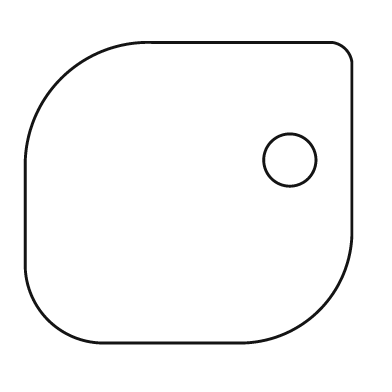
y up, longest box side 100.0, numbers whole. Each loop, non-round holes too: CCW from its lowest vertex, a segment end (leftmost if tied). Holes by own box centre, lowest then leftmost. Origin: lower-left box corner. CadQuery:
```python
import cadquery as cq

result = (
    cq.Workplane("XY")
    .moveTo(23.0, 0.0)
    .lineTo(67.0, 0.0)
    .threePointArc((90.0, 10.0), (100.0, 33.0))
    .lineTo(100.0, 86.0)
    .threePointArc((98.0, 90.0), (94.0, 92.0))
    .lineTo(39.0, 92.0)
    .threePointArc((11.0, 81.0), (0.0, 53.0))
    .lineTo(0.0, 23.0)
    .threePointArc((7.0, 7.0), (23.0, 0.0))
    .close()
    .moveTo(81.0, 56.0)
    .circle(8.0)
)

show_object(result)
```